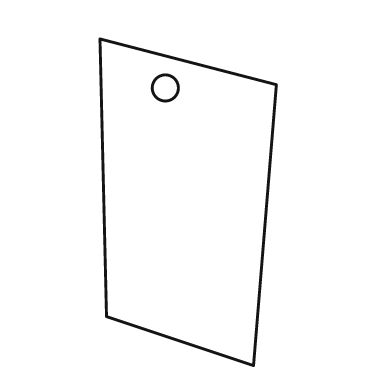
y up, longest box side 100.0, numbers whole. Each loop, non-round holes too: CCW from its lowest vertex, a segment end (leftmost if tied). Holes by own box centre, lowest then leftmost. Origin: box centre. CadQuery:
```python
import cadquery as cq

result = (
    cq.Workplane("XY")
    .moveTo(20.0, -50.0)
    .lineTo(27.0, 36.0)
    .lineTo(-27.0, 50.0)
    .lineTo(-25.0, -35.0)
    .close()
    .moveTo(-7.0, 35.0)
    .circle(4.0)
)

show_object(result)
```